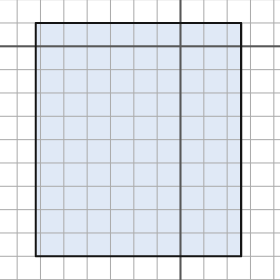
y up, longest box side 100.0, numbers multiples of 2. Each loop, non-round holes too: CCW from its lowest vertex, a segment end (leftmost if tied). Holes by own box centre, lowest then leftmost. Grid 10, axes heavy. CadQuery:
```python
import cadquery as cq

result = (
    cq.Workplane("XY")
    .moveTo(-62.0, -90.0)
    .lineTo(26.0, -90.0)
    .lineTo(26.0, 10.0)
    .lineTo(-62.0, 10.0)
    .close()
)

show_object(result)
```